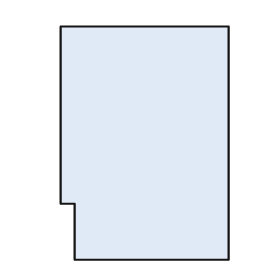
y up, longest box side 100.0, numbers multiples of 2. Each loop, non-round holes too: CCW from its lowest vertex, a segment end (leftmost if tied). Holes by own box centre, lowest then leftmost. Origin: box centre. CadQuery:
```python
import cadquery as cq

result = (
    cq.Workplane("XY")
    .moveTo(-30.0, -50.0)
    .lineTo(36.0, -50.0)
    .lineTo(36.0, 50.0)
    .lineTo(-36.0, 50.0)
    .lineTo(-36.0, -26.0)
    .lineTo(-30.0, -26.0)
    .close()
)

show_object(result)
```